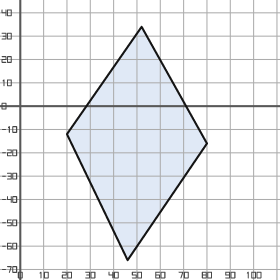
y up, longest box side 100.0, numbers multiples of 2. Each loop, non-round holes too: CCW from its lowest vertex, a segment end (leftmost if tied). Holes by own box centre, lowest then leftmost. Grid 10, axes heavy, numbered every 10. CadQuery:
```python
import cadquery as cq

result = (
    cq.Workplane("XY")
    .moveTo(46.0, -66.0)
    .lineTo(80.0, -16.0)
    .lineTo(52.0, 34.0)
    .lineTo(20.0, -12.0)
    .close()
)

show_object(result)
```